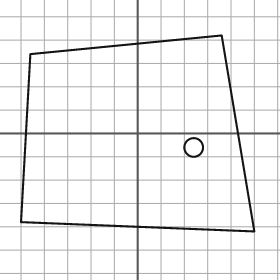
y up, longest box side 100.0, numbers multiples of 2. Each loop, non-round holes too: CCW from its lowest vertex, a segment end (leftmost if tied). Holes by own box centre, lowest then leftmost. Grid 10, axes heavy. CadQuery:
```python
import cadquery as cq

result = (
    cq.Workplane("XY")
    .moveTo(50.0, -42.0)
    .lineTo(36.0, 42.0)
    .lineTo(-46.0, 34.0)
    .lineTo(-50.0, -38.0)
    .close()
    .moveTo(24.0, -6.0)
    .circle(4.0)
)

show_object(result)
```